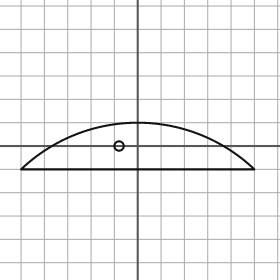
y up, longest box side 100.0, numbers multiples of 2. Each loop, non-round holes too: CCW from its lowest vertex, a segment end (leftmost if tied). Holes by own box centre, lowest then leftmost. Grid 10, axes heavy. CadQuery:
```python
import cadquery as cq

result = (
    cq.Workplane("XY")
    .moveTo(-50.0, -10.0)
    .lineTo(50.0, -10.0)
    .threePointArc((0.0, 10.0), (-50.0, -10.0))
    .close()
    .moveTo(-8.0, 0.0)
    .circle(2.0)
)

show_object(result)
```